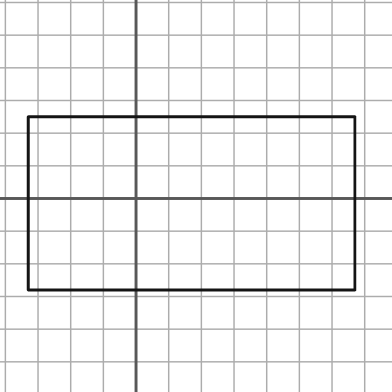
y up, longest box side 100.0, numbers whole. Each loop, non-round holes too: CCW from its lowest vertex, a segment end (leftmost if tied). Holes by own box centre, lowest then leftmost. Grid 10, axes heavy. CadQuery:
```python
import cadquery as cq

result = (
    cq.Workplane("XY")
    .moveTo(-33.0, -28.0)
    .lineTo(67.0, -28.0)
    .lineTo(67.0, 25.0)
    .lineTo(-33.0, 25.0)
    .close()
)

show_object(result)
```